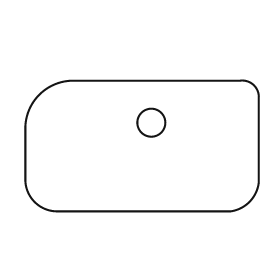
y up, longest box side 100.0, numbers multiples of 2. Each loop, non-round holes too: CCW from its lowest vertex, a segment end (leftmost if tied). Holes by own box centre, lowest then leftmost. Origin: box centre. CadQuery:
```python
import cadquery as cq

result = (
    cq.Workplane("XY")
    .moveTo(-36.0, -28.0)
    .lineTo(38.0, -28.0)
    .threePointArc((46.0, -24.0), (50.0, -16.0))
    .lineTo(50.0, 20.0)
    .threePointArc((48.0, 26.0), (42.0, 28.0))
    .lineTo(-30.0, 28.0)
    .threePointArc((-44.0, 22.0), (-50.0, 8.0))
    .lineTo(-50.0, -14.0)
    .threePointArc((-46.0, -24.0), (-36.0, -28.0))
    .close()
    .moveTo(4.0, 10.0)
    .circle(6.0)
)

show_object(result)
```